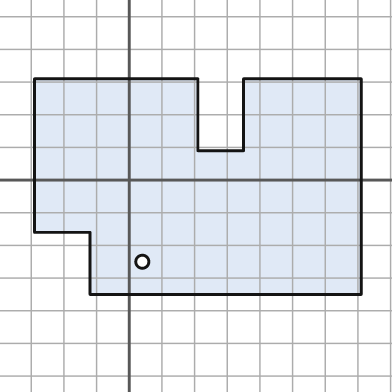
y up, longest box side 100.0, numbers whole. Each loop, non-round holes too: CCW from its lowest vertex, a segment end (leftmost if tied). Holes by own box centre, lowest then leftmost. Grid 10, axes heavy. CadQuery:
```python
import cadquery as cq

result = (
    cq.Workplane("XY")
    .moveTo(-12.0, -35.0)
    .lineTo(71.0, -35.0)
    .lineTo(71.0, 31.0)
    .lineTo(35.0, 31.0)
    .lineTo(35.0, 9.0)
    .lineTo(21.0, 9.0)
    .lineTo(21.0, 31.0)
    .lineTo(-29.0, 31.0)
    .lineTo(-29.0, -16.0)
    .lineTo(-12.0, -16.0)
    .close()
    .moveTo(4.0, -25.0)
    .circle(2.0)
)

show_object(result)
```